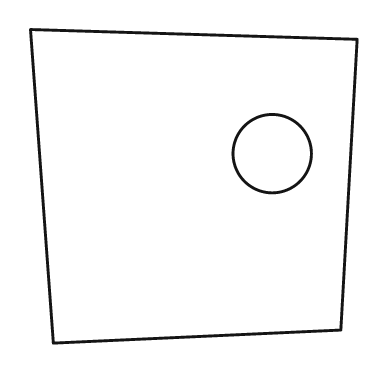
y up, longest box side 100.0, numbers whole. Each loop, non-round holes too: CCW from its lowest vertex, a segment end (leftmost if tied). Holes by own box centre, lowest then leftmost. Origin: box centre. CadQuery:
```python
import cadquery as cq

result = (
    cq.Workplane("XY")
    .moveTo(-43.0, -48.0)
    .lineTo(45.0, -44.0)
    .lineTo(50.0, 45.0)
    .lineTo(-50.0, 48.0)
    .close()
    .moveTo(24.0, 10.0)
    .circle(12.0)
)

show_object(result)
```